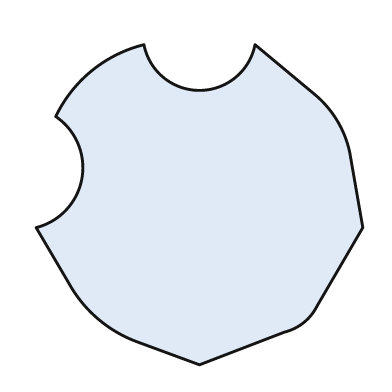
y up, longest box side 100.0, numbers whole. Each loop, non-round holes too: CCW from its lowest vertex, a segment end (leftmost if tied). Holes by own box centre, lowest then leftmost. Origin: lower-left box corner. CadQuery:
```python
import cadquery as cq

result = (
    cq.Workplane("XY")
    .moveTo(50.0, 0.0)
    .lineTo(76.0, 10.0)
    .threePointArc((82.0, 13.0), (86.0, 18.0))
    .lineTo(100.0, 42.0)
    .lineTo(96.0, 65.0)
    .threePointArc((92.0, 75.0), (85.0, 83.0))
    .lineTo(67.0, 98.0)
    .threePointArc((50.0, 84.0), (33.0, 98.0))
    .threePointArc((17.0, 90.0), (6.0, 76.0))
    .threePointArc((14.0, 57.0), (0.0, 42.0))
    .lineTo(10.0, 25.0)
    .threePointArc((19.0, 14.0), (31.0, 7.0))
    .close()
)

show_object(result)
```